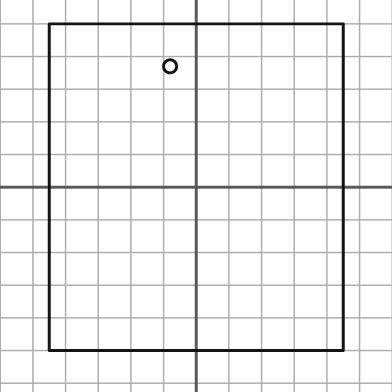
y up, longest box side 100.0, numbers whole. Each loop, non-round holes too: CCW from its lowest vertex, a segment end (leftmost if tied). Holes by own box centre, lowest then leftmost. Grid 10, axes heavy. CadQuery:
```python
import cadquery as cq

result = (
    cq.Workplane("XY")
    .moveTo(-45.0, -50.0)
    .lineTo(45.0, -50.0)
    .lineTo(45.0, 50.0)
    .lineTo(-45.0, 50.0)
    .close()
    .moveTo(-8.0, 37.0)
    .circle(2.0)
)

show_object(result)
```